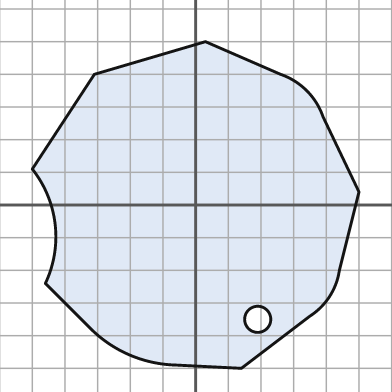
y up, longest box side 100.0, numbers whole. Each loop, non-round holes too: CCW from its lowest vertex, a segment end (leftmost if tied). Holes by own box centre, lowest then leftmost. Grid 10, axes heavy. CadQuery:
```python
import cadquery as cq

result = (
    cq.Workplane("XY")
    .moveTo(14.0, -50.0)
    .lineTo(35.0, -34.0)
    .threePointArc((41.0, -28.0), (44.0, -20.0))
    .lineTo(50.0, 4.0)
    .lineTo(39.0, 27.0)
    .threePointArc((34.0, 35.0), (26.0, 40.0))
    .lineTo(3.0, 50.0)
    .lineTo(-31.0, 40.0)
    .lineTo(-50.0, 11.0)
    .threePointArc((-43.0, -6.0), (-46.0, -24.0))
    .lineTo(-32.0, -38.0)
    .threePointArc((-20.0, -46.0), (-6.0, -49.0))
    .close()
    .moveTo(19.0, -35.0)
    .circle(4.0)
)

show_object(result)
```